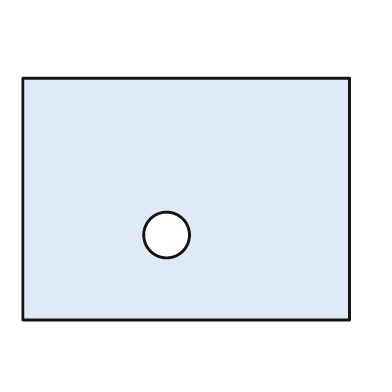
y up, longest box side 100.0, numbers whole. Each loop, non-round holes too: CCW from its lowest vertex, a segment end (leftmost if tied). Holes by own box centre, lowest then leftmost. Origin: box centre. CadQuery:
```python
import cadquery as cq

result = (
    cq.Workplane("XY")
    .moveTo(-50.0, -37.0)
    .lineTo(50.0, -37.0)
    .lineTo(50.0, 37.0)
    .lineTo(-50.0, 37.0)
    .close()
    .moveTo(-6.0, -11.0)
    .circle(7.0)
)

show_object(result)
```